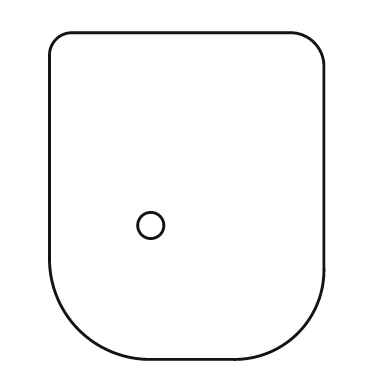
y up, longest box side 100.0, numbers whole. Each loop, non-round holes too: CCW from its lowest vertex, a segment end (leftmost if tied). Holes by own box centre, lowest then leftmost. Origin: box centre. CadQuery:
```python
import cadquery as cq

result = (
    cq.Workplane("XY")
    .moveTo(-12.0, -50.0)
    .lineTo(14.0, -50.0)
    .threePointArc((34.0, -42.0), (42.0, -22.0))
    .lineTo(42.0, 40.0)
    .threePointArc((39.0, 47.0), (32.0, 50.0))
    .lineTo(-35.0, 50.0)
    .threePointArc((-40.0, 48.0), (-42.0, 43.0))
    .lineTo(-42.0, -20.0)
    .threePointArc((-33.0, -41.0), (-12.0, -50.0))
    .close()
    .moveTo(-11.0, -9.0)
    .circle(4.0)
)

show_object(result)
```